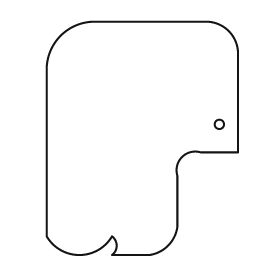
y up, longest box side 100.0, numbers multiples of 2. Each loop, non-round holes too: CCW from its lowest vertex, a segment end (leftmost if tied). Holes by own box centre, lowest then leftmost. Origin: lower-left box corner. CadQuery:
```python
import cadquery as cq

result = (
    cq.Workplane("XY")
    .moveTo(28.0, 0.0)
    .lineTo(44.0, 0.0)
    .threePointArc((52.0, 4.0), (56.0, 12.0))
    .lineTo(56.0, 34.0)
    .threePointArc((58.0, 42.0), (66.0, 44.0))
    .lineTo(82.0, 44.0)
    .lineTo(82.0, 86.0)
    .threePointArc((78.0, 96.0), (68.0, 100.0))
    .lineTo(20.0, 100.0)
    .threePointArc((6.0, 94.0), (0.0, 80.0))
    .lineTo(0.0, 8.0)
    .threePointArc((14.0, 0.0), (28.0, 8.0))
    .threePointArc((30.0, 4.0), (28.0, 0.0))
    .close()
    .moveTo(74.0, 56.0)
    .circle(2.0)
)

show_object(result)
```